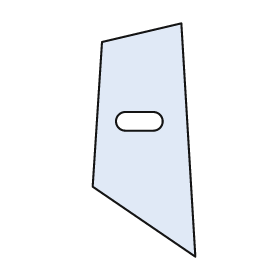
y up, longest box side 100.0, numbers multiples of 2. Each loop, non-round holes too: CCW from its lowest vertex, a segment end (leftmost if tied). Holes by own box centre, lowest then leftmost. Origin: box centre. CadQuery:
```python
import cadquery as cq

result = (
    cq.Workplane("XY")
    .moveTo(22.0, -50.0)
    .lineTo(16.0, 50.0)
    .lineTo(-18.0, 42.0)
    .lineTo(-22.0, -20.0)
    .close()
    .moveTo(-8.0, 4.0)
    .lineTo(4.0, 4.0)
    .threePointArc((8.0, 8.0), (4.0, 12.0))
    .lineTo(-8.0, 12.0)
    .threePointArc((-12.0, 8.0), (-8.0, 4.0))
    .close()
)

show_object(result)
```